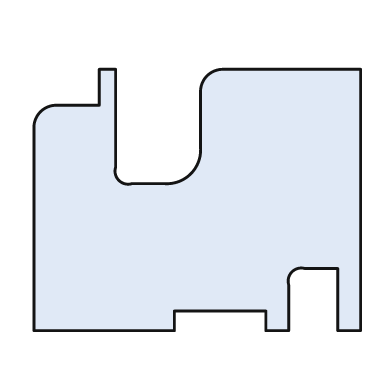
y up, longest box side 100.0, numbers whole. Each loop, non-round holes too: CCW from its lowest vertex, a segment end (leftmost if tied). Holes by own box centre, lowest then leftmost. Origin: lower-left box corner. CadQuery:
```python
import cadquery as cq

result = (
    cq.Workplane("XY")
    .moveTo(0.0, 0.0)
    .lineTo(43.0, 0.0)
    .lineTo(43.0, 6.0)
    .lineTo(71.0, 6.0)
    .lineTo(71.0, 0.0)
    .lineTo(78.0, 0.0)
    .lineTo(78.0, 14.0)
    .threePointArc((79.0, 18.0), (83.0, 19.0))
    .lineTo(93.0, 19.0)
    .lineTo(93.0, 0.0)
    .lineTo(100.0, 0.0)
    .lineTo(100.0, 80.0)
    .lineTo(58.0, 80.0)
    .threePointArc((53.0, 78.0), (51.0, 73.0))
    .lineTo(51.0, 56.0)
    .threePointArc((48.0, 48.0), (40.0, 45.0))
    .lineTo(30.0, 45.0)
    .threePointArc((26.0, 46.0), (25.0, 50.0))
    .lineTo(25.0, 80.0)
    .lineTo(20.0, 80.0)
    .lineTo(20.0, 69.0)
    .lineTo(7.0, 69.0)
    .threePointArc((2.0, 67.0), (0.0, 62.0))
    .close()
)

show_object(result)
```